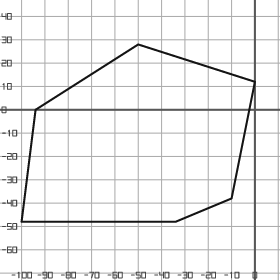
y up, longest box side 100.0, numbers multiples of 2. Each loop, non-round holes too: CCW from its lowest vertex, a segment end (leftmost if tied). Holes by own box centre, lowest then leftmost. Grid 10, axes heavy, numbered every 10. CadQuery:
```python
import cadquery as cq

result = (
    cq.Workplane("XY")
    .moveTo(-100.0, -48.0)
    .lineTo(-34.0, -48.0)
    .lineTo(-10.0, -38.0)
    .lineTo(0.0, 12.0)
    .lineTo(-50.0, 28.0)
    .lineTo(-94.0, 0.0)
    .close()
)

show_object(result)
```